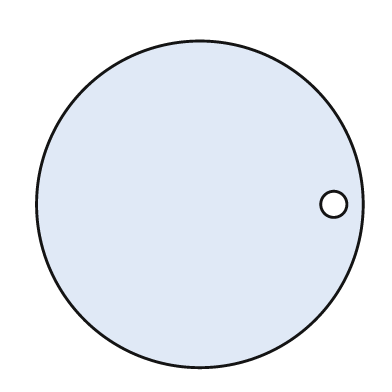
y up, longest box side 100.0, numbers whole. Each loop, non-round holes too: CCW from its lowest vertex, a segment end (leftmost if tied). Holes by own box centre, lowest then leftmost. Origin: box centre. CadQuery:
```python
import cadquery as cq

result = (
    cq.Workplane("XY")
    .moveTo(0.0, 0.0)
    .circle(50.0)
    .moveTo(41.0, 0.0)
    .circle(4.0)
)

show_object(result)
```